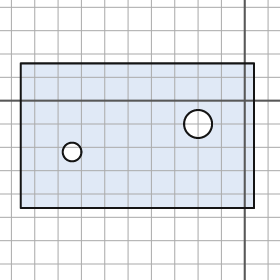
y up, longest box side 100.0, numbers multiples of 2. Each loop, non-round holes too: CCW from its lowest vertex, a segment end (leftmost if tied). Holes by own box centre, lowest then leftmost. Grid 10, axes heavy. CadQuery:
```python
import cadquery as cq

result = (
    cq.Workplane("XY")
    .moveTo(-96.0, -46.0)
    .lineTo(4.0, -46.0)
    .lineTo(4.0, 16.0)
    .lineTo(-96.0, 16.0)
    .close()
    .moveTo(-74.0, -22.0)
    .circle(4.0)
    .moveTo(-20.0, -10.0)
    .circle(6.0)
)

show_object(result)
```